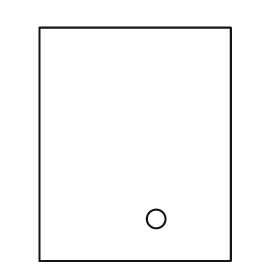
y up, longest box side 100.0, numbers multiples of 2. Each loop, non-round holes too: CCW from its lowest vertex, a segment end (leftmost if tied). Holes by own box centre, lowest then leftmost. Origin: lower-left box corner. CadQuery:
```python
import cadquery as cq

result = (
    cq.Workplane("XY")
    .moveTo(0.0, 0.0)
    .lineTo(82.0, 0.0)
    .lineTo(82.0, 100.0)
    .lineTo(0.0, 100.0)
    .close()
    .moveTo(50.0, 18.0)
    .circle(4.0)
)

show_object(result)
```